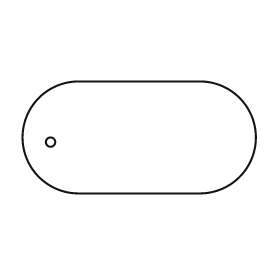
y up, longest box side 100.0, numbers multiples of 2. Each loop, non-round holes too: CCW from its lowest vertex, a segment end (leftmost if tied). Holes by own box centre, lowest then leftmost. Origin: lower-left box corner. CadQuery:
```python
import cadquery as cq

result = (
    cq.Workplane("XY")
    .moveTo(24.0, 0.0)
    .lineTo(76.0, 0.0)
    .threePointArc((100.0, 24.0), (76.0, 48.0))
    .lineTo(24.0, 48.0)
    .threePointArc((0.0, 24.0), (24.0, 0.0))
    .close()
    .moveTo(12.0, 22.0)
    .circle(2.0)
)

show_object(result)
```